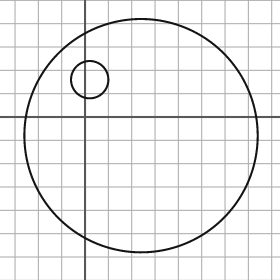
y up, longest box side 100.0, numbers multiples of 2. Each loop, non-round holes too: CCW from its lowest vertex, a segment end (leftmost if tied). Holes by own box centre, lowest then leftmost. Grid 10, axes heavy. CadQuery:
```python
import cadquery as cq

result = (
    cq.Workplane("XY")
    .moveTo(24.0, -8.0)
    .circle(50.0)
    .moveTo(2.0, 16.0)
    .circle(8.0)
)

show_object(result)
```